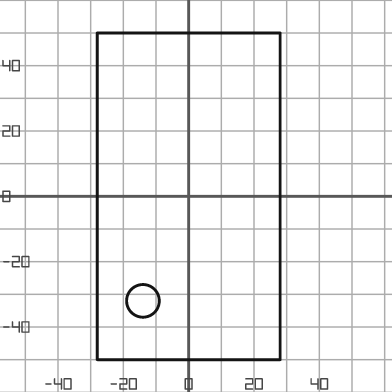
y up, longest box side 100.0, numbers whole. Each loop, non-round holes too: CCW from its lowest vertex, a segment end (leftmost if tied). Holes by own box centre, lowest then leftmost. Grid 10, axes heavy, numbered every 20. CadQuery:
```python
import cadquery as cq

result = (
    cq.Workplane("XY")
    .moveTo(-28.0, -50.0)
    .lineTo(28.0, -50.0)
    .lineTo(28.0, 50.0)
    .lineTo(-28.0, 50.0)
    .close()
    .moveTo(-14.0, -32.0)
    .circle(5.0)
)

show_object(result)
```